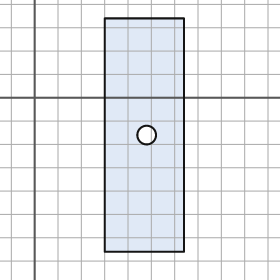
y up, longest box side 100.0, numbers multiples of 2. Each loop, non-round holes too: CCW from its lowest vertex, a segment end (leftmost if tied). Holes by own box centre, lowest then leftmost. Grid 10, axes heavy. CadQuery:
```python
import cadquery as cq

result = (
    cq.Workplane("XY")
    .moveTo(30.0, -66.0)
    .lineTo(64.0, -66.0)
    .lineTo(64.0, 34.0)
    .lineTo(30.0, 34.0)
    .close()
    .moveTo(48.0, -16.0)
    .circle(4.0)
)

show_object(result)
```